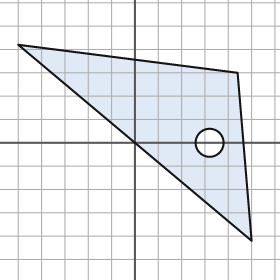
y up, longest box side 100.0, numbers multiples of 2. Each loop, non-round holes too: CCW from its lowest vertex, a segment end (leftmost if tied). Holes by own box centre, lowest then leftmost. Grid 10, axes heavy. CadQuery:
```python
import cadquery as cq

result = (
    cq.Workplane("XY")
    .moveTo(50.0, -42.0)
    .lineTo(44.0, 30.0)
    .lineTo(-50.0, 42.0)
    .close()
    .moveTo(32.0, 0.0)
    .circle(6.0)
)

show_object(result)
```